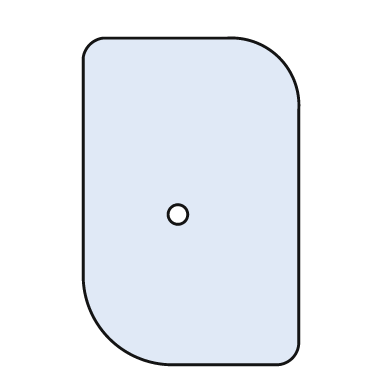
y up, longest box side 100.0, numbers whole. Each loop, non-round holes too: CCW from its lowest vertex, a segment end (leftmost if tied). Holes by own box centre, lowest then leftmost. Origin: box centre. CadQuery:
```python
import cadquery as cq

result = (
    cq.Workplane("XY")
    .moveTo(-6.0, -50.0)
    .lineTo(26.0, -50.0)
    .threePointArc((31.0, -48.0), (33.0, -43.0))
    .lineTo(33.0, 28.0)
    .threePointArc((27.0, 44.0), (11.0, 50.0))
    .lineTo(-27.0, 50.0)
    .threePointArc((-31.0, 48.0), (-33.0, 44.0))
    .lineTo(-33.0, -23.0)
    .threePointArc((-25.0, -42.0), (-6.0, -50.0))
    .close()
    .moveTo(-4.0, -4.0)
    .circle(3.0)
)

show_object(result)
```